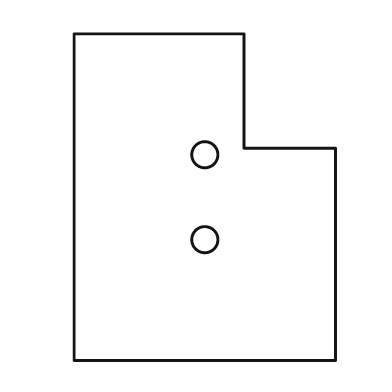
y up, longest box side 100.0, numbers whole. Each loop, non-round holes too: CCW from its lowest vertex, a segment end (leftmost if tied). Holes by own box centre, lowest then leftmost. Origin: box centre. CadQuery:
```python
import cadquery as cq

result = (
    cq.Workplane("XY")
    .moveTo(-40.0, -50.0)
    .lineTo(40.0, -50.0)
    .lineTo(40.0, 15.0)
    .lineTo(12.0, 15.0)
    .lineTo(12.0, 50.0)
    .lineTo(-40.0, 50.0)
    .close()
    .moveTo(0.0, -13.0)
    .circle(4.0)
    .moveTo(0.0, 13.0)
    .circle(4.0)
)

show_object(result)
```